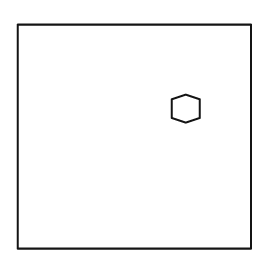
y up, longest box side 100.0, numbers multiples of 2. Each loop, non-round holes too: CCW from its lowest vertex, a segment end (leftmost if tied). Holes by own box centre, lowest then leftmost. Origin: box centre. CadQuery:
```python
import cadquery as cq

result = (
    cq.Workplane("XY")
    .moveTo(-50.0, -48.0)
    .lineTo(50.0, -48.0)
    .lineTo(50.0, 48.0)
    .lineTo(-50.0, 48.0)
    .close()
    .moveTo(22.0, 6.0)
    .lineTo(28.0, 8.0)
    .lineTo(28.0, 16.0)
    .lineTo(22.0, 18.0)
    .lineTo(16.0, 16.0)
    .lineTo(16.0, 8.0)
    .close()
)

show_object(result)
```